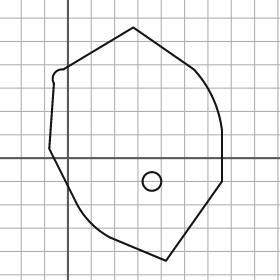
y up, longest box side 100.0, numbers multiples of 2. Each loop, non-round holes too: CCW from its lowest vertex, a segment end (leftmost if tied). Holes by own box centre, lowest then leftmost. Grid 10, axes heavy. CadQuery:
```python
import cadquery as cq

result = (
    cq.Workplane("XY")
    .moveTo(42.0, -44.0)
    .lineTo(66.0, -10.0)
    .lineTo(66.0, 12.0)
    .threePointArc((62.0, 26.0), (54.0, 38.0))
    .lineTo(28.0, 56.0)
    .lineTo(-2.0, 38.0)
    .threePointArc((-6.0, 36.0), (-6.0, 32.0))
    .lineTo(-8.0, 4.0)
    .lineTo(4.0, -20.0)
    .threePointArc((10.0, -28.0), (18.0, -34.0))
    .close()
    .moveTo(36.0, -10.0)
    .circle(4.0)
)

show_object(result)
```